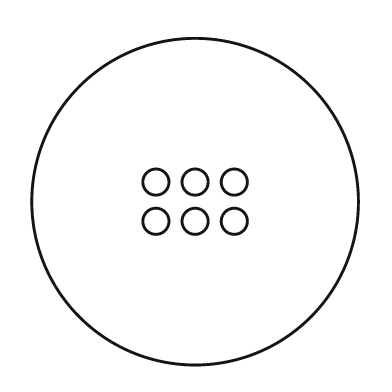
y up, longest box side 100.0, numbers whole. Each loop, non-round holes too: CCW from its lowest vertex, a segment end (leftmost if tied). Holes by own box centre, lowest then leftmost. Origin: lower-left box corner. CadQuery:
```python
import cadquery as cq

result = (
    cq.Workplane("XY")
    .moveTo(50.0, 50.0)
    .circle(50.0)
    .moveTo(38.0, 44.0)
    .circle(4.0)
    .moveTo(50.0, 44.0)
    .circle(4.0)
    .moveTo(62.0, 44.0)
    .circle(4.0)
    .moveTo(38.0, 56.0)
    .circle(4.0)
    .moveTo(50.0, 56.0)
    .circle(4.0)
    .moveTo(62.0, 56.0)
    .circle(4.0)
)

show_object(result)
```